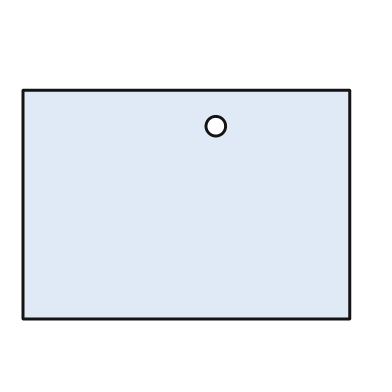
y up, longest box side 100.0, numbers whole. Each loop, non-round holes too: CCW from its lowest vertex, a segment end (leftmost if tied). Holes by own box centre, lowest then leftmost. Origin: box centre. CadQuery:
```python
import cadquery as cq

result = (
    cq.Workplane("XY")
    .moveTo(-50.0, -35.0)
    .lineTo(50.0, -35.0)
    .lineTo(50.0, 35.0)
    .lineTo(-50.0, 35.0)
    .close()
    .moveTo(9.0, 24.0)
    .circle(3.0)
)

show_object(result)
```